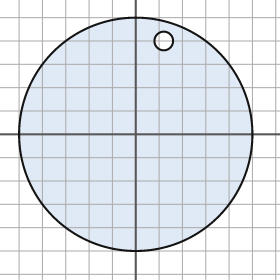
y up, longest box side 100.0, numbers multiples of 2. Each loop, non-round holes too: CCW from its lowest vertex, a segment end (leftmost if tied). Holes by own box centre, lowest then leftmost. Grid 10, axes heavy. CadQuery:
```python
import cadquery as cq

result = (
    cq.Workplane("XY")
    .moveTo(0.0, 0.0)
    .circle(50.0)
    .moveTo(12.0, 40.0)
    .circle(4.0)
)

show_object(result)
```